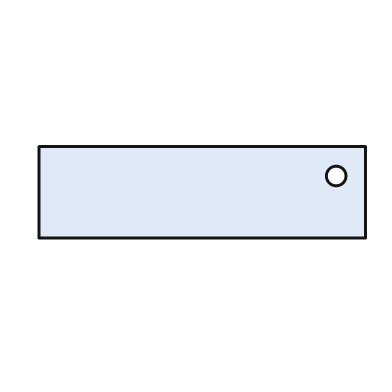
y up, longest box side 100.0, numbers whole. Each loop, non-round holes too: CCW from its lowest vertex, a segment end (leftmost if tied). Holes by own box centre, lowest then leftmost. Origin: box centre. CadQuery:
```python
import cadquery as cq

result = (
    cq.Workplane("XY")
    .moveTo(-50.0, -14.0)
    .lineTo(50.0, -14.0)
    .lineTo(50.0, 14.0)
    .lineTo(-50.0, 14.0)
    .close()
    .moveTo(41.0, 5.0)
    .circle(3.0)
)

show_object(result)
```